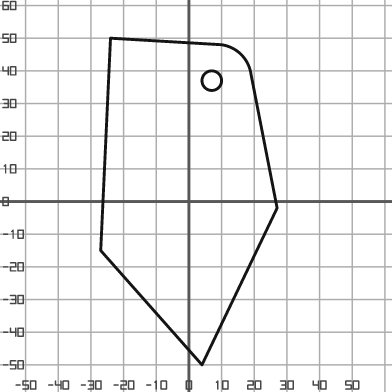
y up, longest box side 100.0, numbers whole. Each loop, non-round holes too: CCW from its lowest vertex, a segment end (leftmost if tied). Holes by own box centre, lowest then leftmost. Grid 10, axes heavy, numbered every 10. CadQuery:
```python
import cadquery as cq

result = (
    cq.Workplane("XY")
    .moveTo(4.0, -50.0)
    .lineTo(27.0, -2.0)
    .lineTo(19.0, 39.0)
    .threePointArc((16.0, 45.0), (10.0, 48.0))
    .lineTo(-24.0, 50.0)
    .lineTo(-27.0, -15.0)
    .close()
    .moveTo(7.0, 37.0)
    .circle(3.0)
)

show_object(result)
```